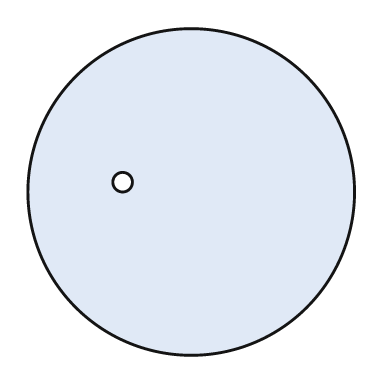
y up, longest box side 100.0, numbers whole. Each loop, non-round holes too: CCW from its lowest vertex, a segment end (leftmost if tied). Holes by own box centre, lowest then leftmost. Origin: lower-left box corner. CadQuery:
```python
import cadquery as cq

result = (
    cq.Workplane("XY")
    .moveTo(50.0, 50.0)
    .circle(50.0)
    .moveTo(29.0, 53.0)
    .circle(3.0)
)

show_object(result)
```